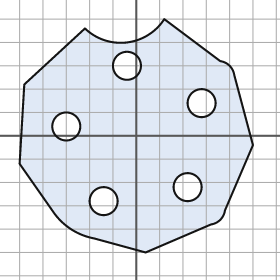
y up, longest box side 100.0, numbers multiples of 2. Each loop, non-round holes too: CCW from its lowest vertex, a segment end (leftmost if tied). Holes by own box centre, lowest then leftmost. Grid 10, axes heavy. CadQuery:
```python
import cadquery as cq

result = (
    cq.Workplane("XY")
    .moveTo(4.0, -50.0)
    .lineTo(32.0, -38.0)
    .threePointArc((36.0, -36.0), (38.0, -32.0))
    .lineTo(50.0, -4.0)
    .lineTo(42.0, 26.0)
    .threePointArc((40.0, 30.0), (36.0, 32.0))
    .lineTo(12.0, 50.0)
    .threePointArc((-4.0, 40.0), (-22.0, 46.0))
    .lineTo(-48.0, 22.0)
    .lineTo(-50.0, -12.0)
    .lineTo(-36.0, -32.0)
    .threePointArc((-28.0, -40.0), (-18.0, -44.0))
    .close()
    .moveTo(-14.0, -28.0)
    .circle(6.0)
    .moveTo(22.0, -22.0)
    .circle(6.0)
    .moveTo(-30.0, 4.0)
    .circle(6.0)
    .moveTo(28.0, 14.0)
    .circle(6.0)
    .moveTo(-4.0, 30.0)
    .circle(6.0)
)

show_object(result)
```